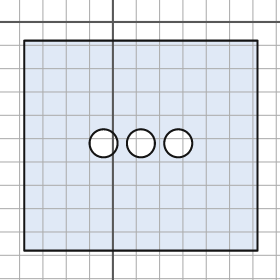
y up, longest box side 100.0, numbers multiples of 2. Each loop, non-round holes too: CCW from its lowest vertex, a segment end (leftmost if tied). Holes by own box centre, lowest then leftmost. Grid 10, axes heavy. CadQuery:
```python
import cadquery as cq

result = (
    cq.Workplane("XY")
    .moveTo(-38.0, -98.0)
    .lineTo(62.0, -98.0)
    .lineTo(62.0, -8.0)
    .lineTo(-38.0, -8.0)
    .close()
    .moveTo(-4.0, -52.0)
    .circle(6.0)
    .moveTo(12.0, -52.0)
    .circle(6.0)
    .moveTo(28.0, -52.0)
    .circle(6.0)
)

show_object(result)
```